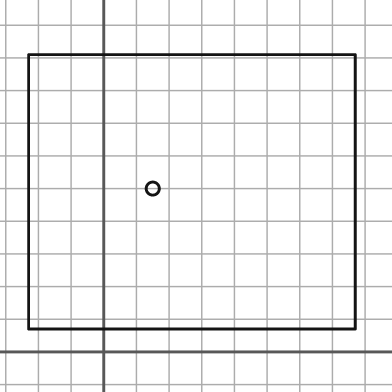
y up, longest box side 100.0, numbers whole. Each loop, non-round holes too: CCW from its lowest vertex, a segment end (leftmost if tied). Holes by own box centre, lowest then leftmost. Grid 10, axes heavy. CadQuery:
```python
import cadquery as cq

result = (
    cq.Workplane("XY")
    .moveTo(-23.0, 7.0)
    .lineTo(77.0, 7.0)
    .lineTo(77.0, 91.0)
    .lineTo(-23.0, 91.0)
    .close()
    .moveTo(15.0, 50.0)
    .circle(2.0)
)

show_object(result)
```